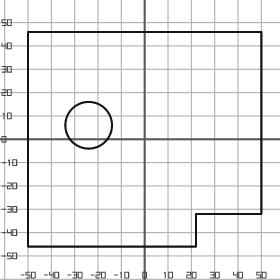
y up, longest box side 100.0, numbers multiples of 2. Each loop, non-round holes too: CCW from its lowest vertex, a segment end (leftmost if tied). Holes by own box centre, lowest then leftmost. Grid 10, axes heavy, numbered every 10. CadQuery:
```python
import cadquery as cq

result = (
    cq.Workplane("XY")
    .moveTo(-50.0, -46.0)
    .lineTo(22.0, -46.0)
    .lineTo(22.0, -32.0)
    .lineTo(50.0, -32.0)
    .lineTo(50.0, 46.0)
    .lineTo(-50.0, 46.0)
    .close()
    .moveTo(-24.0, 6.0)
    .circle(10.0)
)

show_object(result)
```